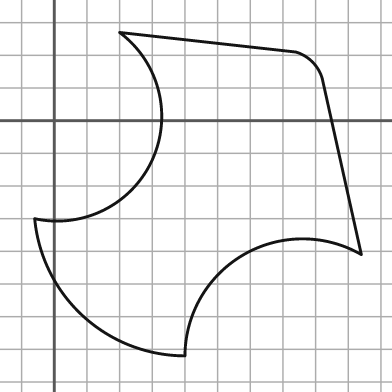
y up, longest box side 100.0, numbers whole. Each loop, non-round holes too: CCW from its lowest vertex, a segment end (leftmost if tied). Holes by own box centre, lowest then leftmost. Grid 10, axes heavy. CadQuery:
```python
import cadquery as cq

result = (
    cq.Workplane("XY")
    .moveTo(40.0, -72.0)
    .threePointArc((58.0, -41.0), (94.0, -41.0))
    .lineTo(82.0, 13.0)
    .threePointArc((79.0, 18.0), (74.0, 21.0))
    .lineTo(20.0, 27.0)
    .threePointArc((30.0, -12.0), (-6.0, -30.0))
    .threePointArc((9.0, -60.0), (40.0, -72.0))
    .close()
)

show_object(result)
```